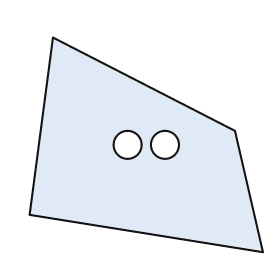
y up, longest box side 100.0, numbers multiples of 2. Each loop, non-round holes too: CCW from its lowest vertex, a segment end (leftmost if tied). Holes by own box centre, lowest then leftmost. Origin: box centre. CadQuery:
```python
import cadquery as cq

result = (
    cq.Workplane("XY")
    .moveTo(50.0, -46.0)
    .lineTo(38.0, 6.0)
    .lineTo(-40.0, 46.0)
    .lineTo(-50.0, -30.0)
    .close()
    .moveTo(-8.0, 0.0)
    .circle(6.0)
    .moveTo(8.0, 0.0)
    .circle(6.0)
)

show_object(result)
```